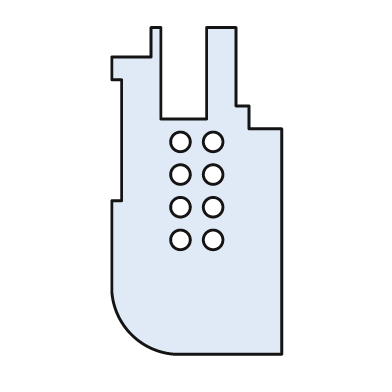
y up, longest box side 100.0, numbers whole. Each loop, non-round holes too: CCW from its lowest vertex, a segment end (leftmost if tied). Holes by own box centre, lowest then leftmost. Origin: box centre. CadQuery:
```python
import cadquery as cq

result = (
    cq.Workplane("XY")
    .moveTo(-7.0, -50.0)
    .lineTo(26.0, -50.0)
    .lineTo(26.0, 19.0)
    .lineTo(16.0, 19.0)
    .lineTo(16.0, 26.0)
    .lineTo(12.0, 26.0)
    .lineTo(12.0, 50.0)
    .lineTo(3.0, 50.0)
    .lineTo(3.0, 22.0)
    .lineTo(-11.0, 22.0)
    .lineTo(-11.0, 50.0)
    .lineTo(-14.0, 50.0)
    .lineTo(-14.0, 41.0)
    .lineTo(-26.0, 41.0)
    .lineTo(-26.0, 34.0)
    .lineTo(-23.0, 34.0)
    .lineTo(-23.0, -3.0)
    .lineTo(-26.0, -3.0)
    .lineTo(-26.0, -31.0)
    .threePointArc((-20.0, -44.0), (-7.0, -50.0))
    .close()
    .moveTo(-5.0, -15.0)
    .circle(3.0)
    .moveTo(5.0, -15.0)
    .circle(3.0)
    .moveTo(-5.0, -5.0)
    .circle(3.0)
    .moveTo(5.0, -5.0)
    .circle(3.0)
    .moveTo(-5.0, 5.0)
    .circle(3.0)
    .moveTo(5.0, 5.0)
    .circle(3.0)
    .moveTo(-5.0, 15.0)
    .circle(3.0)
    .moveTo(5.0, 15.0)
    .circle(3.0)
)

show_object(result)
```